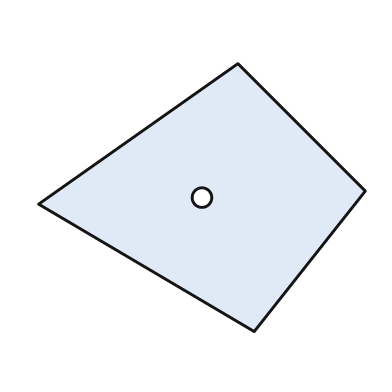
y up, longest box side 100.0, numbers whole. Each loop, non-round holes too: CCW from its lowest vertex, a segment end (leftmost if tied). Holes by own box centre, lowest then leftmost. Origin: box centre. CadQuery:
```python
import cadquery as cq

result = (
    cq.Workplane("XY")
    .moveTo(16.0, -41.0)
    .lineTo(50.0, 2.0)
    .lineTo(11.0, 41.0)
    .lineTo(-50.0, -2.0)
    .close()
    .moveTo(0.0, 0.0)
    .circle(3.0)
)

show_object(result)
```